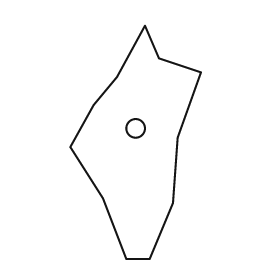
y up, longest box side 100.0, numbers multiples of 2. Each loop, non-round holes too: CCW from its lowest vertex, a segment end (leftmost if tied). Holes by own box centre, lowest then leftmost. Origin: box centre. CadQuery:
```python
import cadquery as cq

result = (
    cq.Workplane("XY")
    .moveTo(-4.0, -50.0)
    .lineTo(6.0, -50.0)
    .lineTo(16.0, -26.0)
    .lineTo(18.0, 2.0)
    .lineTo(28.0, 30.0)
    .lineTo(10.0, 36.0)
    .lineTo(4.0, 50.0)
    .lineTo(-8.0, 28.0)
    .lineTo(-18.0, 16.0)
    .lineTo(-28.0, -2.0)
    .lineTo(-14.0, -24.0)
    .close()
    .moveTo(0.0, 6.0)
    .circle(4.0)
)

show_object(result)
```